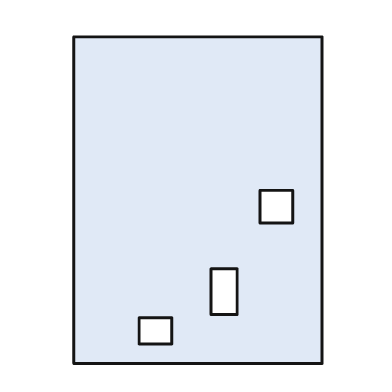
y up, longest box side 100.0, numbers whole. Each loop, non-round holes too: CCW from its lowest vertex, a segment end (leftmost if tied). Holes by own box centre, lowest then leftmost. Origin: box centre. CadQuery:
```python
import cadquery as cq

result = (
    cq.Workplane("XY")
    .moveTo(-38.0, -50.0)
    .lineTo(38.0, -50.0)
    .lineTo(38.0, 50.0)
    .lineTo(-38.0, 50.0)
    .close()
    .moveTo(-18.0, -44.0)
    .lineTo(-8.0, -44.0)
    .lineTo(-8.0, -36.0)
    .lineTo(-18.0, -36.0)
    .close()
    .moveTo(4.0, -35.0)
    .lineTo(12.0, -35.0)
    .lineTo(12.0, -21.0)
    .lineTo(4.0, -21.0)
    .close()
    .moveTo(19.0, -7.0)
    .lineTo(29.0, -7.0)
    .lineTo(29.0, 3.0)
    .lineTo(19.0, 3.0)
    .close()
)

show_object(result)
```